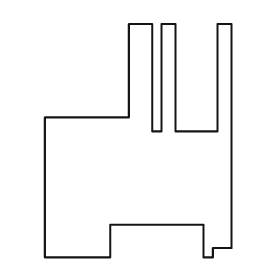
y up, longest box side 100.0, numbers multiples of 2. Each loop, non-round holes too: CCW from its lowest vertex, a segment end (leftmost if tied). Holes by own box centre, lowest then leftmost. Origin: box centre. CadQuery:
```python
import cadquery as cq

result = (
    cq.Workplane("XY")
    .moveTo(-40.0, -50.0)
    .lineTo(-12.0, -50.0)
    .lineTo(-12.0, -36.0)
    .lineTo(28.0, -36.0)
    .lineTo(28.0, -50.0)
    .lineTo(32.0, -50.0)
    .lineTo(32.0, -46.0)
    .lineTo(40.0, -46.0)
    .lineTo(40.0, 50.0)
    .lineTo(34.0, 50.0)
    .lineTo(34.0, 4.0)
    .lineTo(16.0, 4.0)
    .lineTo(16.0, 50.0)
    .lineTo(10.0, 50.0)
    .lineTo(10.0, 4.0)
    .lineTo(6.0, 4.0)
    .lineTo(6.0, 50.0)
    .lineTo(-4.0, 50.0)
    .lineTo(-4.0, 10.0)
    .lineTo(-40.0, 10.0)
    .close()
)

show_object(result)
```